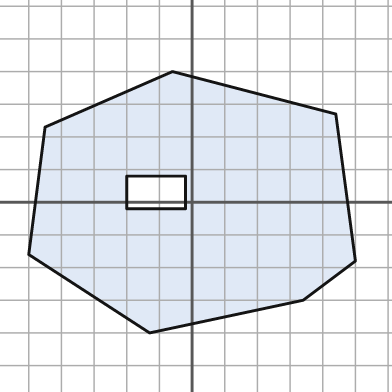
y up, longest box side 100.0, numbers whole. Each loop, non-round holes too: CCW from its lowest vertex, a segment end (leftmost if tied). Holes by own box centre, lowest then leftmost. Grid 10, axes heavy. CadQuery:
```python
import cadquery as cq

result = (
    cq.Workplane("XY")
    .moveTo(-13.0, -40.0)
    .lineTo(34.0, -30.0)
    .lineTo(50.0, -18.0)
    .lineTo(44.0, 27.0)
    .lineTo(-6.0, 40.0)
    .lineTo(-45.0, 23.0)
    .lineTo(-50.0, -16.0)
    .close()
    .moveTo(-20.0, -2.0)
    .lineTo(-2.0, -2.0)
    .lineTo(-2.0, 8.0)
    .lineTo(-20.0, 8.0)
    .close()
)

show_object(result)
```